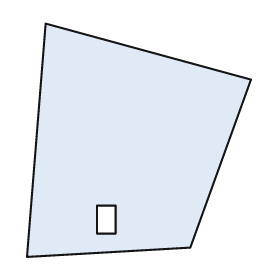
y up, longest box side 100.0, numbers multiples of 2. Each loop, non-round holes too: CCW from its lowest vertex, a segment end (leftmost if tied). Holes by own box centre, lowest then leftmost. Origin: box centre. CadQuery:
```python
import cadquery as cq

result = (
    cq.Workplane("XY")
    .moveTo(-48.0, -50.0)
    .lineTo(22.0, -46.0)
    .lineTo(48.0, 26.0)
    .lineTo(-40.0, 50.0)
    .close()
    .moveTo(-18.0, -40.0)
    .lineTo(-10.0, -40.0)
    .lineTo(-10.0, -28.0)
    .lineTo(-18.0, -28.0)
    .close()
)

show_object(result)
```